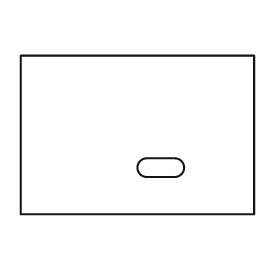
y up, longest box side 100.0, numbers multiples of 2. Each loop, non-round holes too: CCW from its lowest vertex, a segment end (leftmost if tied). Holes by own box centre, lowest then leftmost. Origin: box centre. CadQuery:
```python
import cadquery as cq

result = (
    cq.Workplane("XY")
    .moveTo(-50.0, -34.0)
    .lineTo(50.0, -34.0)
    .lineTo(50.0, 34.0)
    .lineTo(-50.0, 34.0)
    .close()
    .moveTo(4.0, -18.0)
    .lineTo(16.0, -18.0)
    .threePointArc((20.0, -14.0), (16.0, -10.0))
    .lineTo(4.0, -10.0)
    .threePointArc((0.0, -14.0), (4.0, -18.0))
    .close()
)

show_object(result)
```